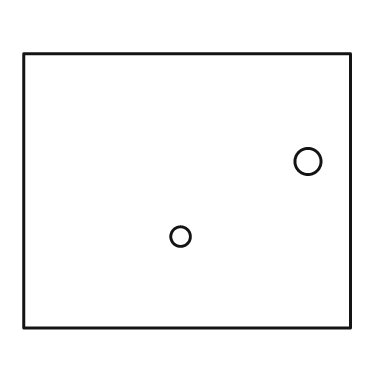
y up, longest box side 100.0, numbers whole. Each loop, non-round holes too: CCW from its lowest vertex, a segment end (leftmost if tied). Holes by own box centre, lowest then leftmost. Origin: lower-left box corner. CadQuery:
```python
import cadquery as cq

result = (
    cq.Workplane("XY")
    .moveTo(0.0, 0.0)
    .lineTo(100.0, 0.0)
    .lineTo(100.0, 84.0)
    .lineTo(0.0, 84.0)
    .close()
    .moveTo(48.0, 28.0)
    .circle(3.0)
    .moveTo(87.0, 51.0)
    .circle(4.0)
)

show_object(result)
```